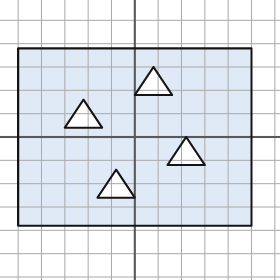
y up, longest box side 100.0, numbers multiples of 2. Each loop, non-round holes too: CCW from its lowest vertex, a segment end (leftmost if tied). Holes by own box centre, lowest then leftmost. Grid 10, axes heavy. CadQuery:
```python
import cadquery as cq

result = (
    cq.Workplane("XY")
    .moveTo(-50.0, -38.0)
    .lineTo(50.0, -38.0)
    .lineTo(50.0, 38.0)
    .lineTo(-50.0, 38.0)
    .close()
    .moveTo(-16.0, -26.0)
    .lineTo(0.0, -26.0)
    .lineTo(-8.0, -14.0)
    .close()
    .moveTo(14.0, -12.0)
    .lineTo(30.0, -12.0)
    .lineTo(22.0, 0.0)
    .close()
    .moveTo(-30.0, 4.0)
    .lineTo(-14.0, 4.0)
    .lineTo(-22.0, 16.0)
    .close()
    .moveTo(0.0, 18.0)
    .lineTo(16.0, 18.0)
    .lineTo(8.0, 30.0)
    .close()
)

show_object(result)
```